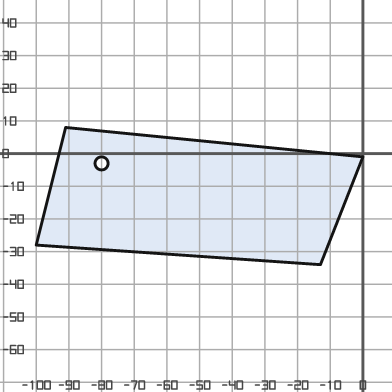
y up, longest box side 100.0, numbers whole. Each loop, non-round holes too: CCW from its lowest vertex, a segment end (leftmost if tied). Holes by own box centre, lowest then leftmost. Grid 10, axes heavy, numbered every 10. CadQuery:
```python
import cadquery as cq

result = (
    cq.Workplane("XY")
    .moveTo(-13.0, -34.0)
    .lineTo(0.0, -1.0)
    .lineTo(-91.0, 8.0)
    .lineTo(-100.0, -28.0)
    .close()
    .moveTo(-80.0, -3.0)
    .circle(2.0)
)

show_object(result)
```